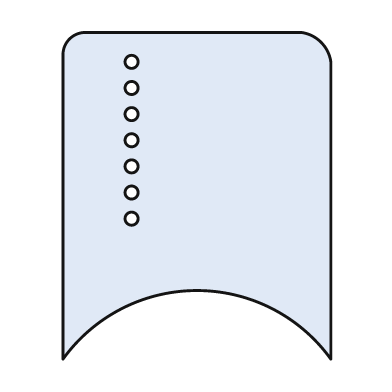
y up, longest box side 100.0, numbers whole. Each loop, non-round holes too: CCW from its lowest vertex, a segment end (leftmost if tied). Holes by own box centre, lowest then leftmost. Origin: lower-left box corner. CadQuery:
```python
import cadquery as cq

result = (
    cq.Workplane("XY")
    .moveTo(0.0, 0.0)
    .threePointArc((41.0, 21.0), (82.0, 0.0))
    .lineTo(82.0, 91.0)
    .threePointArc((79.0, 97.0), (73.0, 100.0))
    .lineTo(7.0, 100.0)
    .threePointArc((2.0, 98.0), (0.0, 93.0))
    .close()
    .moveTo(21.0, 43.0)
    .circle(2.0)
    .moveTo(21.0, 51.0)
    .circle(2.0)
    .moveTo(21.0, 59.0)
    .circle(2.0)
    .moveTo(21.0, 67.0)
    .circle(2.0)
    .moveTo(21.0, 75.0)
    .circle(2.0)
    .moveTo(21.0, 83.0)
    .circle(2.0)
    .moveTo(21.0, 91.0)
    .circle(2.0)
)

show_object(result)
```